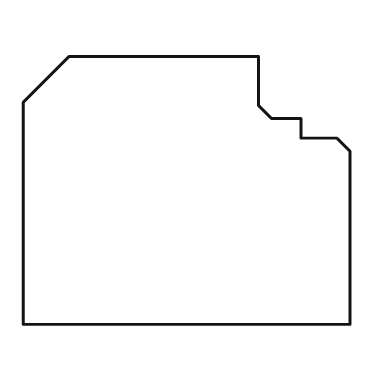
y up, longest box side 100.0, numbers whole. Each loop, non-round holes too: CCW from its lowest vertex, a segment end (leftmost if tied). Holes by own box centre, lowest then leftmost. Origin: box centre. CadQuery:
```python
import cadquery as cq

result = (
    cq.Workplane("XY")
    .moveTo(-50.0, -41.0)
    .lineTo(50.0, -41.0)
    .lineTo(50.0, 12.0)
    .lineTo(46.0, 16.0)
    .lineTo(35.0, 16.0)
    .lineTo(35.0, 22.0)
    .lineTo(26.0, 22.0)
    .lineTo(22.0, 26.0)
    .lineTo(22.0, 41.0)
    .lineTo(-36.0, 41.0)
    .lineTo(-50.0, 27.0)
    .close()
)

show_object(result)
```